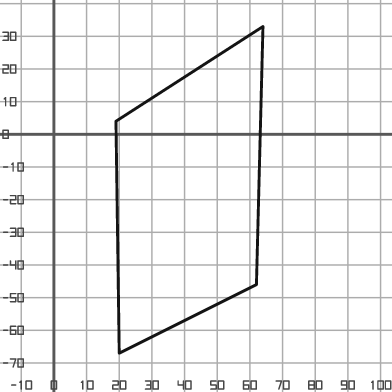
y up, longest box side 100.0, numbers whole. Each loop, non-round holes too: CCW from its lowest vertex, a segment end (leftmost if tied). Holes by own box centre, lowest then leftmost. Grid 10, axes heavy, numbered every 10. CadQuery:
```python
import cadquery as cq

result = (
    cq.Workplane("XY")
    .moveTo(20.0, -67.0)
    .lineTo(62.0, -46.0)
    .lineTo(64.0, 33.0)
    .lineTo(19.0, 4.0)
    .close()
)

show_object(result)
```